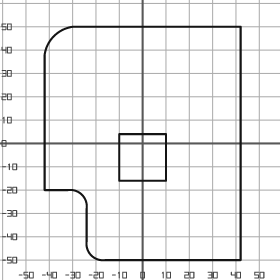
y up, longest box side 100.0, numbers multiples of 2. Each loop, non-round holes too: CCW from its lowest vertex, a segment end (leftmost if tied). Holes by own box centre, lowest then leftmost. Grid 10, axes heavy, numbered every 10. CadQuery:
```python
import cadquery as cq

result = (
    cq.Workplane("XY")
    .moveTo(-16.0, -50.0)
    .lineTo(42.0, -50.0)
    .lineTo(42.0, 50.0)
    .lineTo(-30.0, 50.0)
    .threePointArc((-38.0, 46.0), (-42.0, 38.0))
    .lineTo(-42.0, -20.0)
    .lineTo(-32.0, -20.0)
    .threePointArc((-26.0, -22.0), (-24.0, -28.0))
    .lineTo(-24.0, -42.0)
    .threePointArc((-22.0, -48.0), (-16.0, -50.0))
    .close()
    .moveTo(-10.0, -16.0)
    .lineTo(10.0, -16.0)
    .lineTo(10.0, 4.0)
    .lineTo(-10.0, 4.0)
    .close()
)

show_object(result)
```